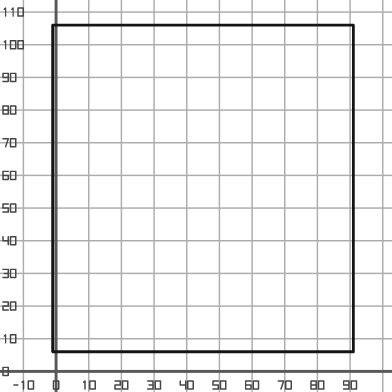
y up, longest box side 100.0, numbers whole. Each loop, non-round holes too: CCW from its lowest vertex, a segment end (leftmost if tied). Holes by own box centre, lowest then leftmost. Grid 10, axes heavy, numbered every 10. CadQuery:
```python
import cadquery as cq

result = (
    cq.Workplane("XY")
    .moveTo(-1.0, 6.0)
    .lineTo(91.0, 6.0)
    .lineTo(91.0, 106.0)
    .lineTo(-1.0, 106.0)
    .close()
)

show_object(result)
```